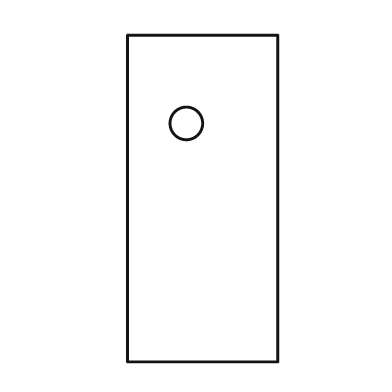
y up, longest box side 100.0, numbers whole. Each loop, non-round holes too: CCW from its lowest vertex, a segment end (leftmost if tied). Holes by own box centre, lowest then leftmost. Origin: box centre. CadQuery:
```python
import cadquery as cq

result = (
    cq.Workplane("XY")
    .moveTo(-23.0, -50.0)
    .lineTo(23.0, -50.0)
    .lineTo(23.0, 50.0)
    .lineTo(-23.0, 50.0)
    .close()
    .moveTo(-5.0, 23.0)
    .circle(5.0)
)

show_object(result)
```